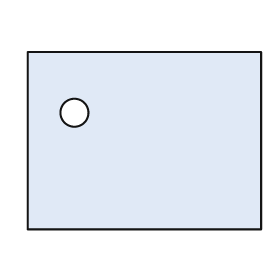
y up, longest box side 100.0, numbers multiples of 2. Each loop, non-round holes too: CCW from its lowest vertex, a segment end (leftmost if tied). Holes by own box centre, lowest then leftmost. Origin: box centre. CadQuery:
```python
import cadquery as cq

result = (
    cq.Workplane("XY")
    .moveTo(-50.0, -38.0)
    .lineTo(50.0, -38.0)
    .lineTo(50.0, 38.0)
    .lineTo(-50.0, 38.0)
    .close()
    .moveTo(-30.0, 12.0)
    .circle(6.0)
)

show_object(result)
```